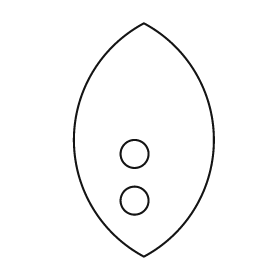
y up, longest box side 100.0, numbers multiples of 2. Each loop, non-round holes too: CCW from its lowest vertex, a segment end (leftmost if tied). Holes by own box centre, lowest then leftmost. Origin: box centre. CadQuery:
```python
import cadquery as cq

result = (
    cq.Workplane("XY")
    .moveTo(0.0, -50.0)
    .threePointArc((30.0, 0.0), (0.0, 50.0))
    .threePointArc((-30.0, 0.0), (0.0, -50.0))
    .close()
    .moveTo(-4.0, -26.0)
    .circle(6.0)
    .moveTo(-4.0, -6.0)
    .circle(6.0)
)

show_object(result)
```